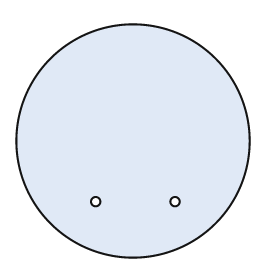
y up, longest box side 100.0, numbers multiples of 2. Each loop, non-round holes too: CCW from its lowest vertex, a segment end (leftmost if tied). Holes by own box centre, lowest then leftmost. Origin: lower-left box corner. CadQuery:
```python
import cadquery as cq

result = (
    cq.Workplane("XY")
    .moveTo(50.0, 50.0)
    .circle(50.0)
    .moveTo(34.0, 24.0)
    .circle(2.0)
    .moveTo(68.0, 24.0)
    .circle(2.0)
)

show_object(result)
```